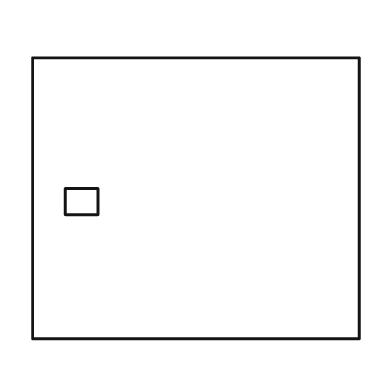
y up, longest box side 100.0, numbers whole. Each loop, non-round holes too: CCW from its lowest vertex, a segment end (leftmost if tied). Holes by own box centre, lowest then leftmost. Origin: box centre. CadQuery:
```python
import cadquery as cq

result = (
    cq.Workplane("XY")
    .moveTo(-50.0, -43.0)
    .lineTo(50.0, -43.0)
    .lineTo(50.0, 43.0)
    .lineTo(-50.0, 43.0)
    .close()
    .moveTo(-40.0, -5.0)
    .lineTo(-30.0, -5.0)
    .lineTo(-30.0, 3.0)
    .lineTo(-40.0, 3.0)
    .close()
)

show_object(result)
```